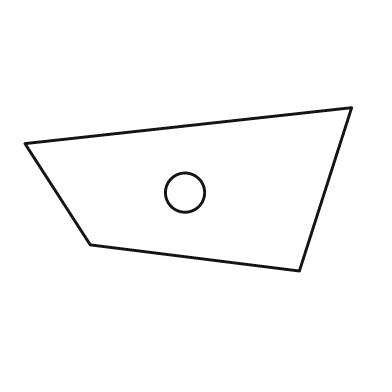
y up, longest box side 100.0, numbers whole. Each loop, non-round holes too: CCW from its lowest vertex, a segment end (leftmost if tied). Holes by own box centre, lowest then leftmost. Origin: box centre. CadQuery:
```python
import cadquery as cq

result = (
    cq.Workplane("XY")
    .moveTo(34.0, -25.0)
    .lineTo(50.0, 25.0)
    .lineTo(-50.0, 14.0)
    .lineTo(-30.0, -17.0)
    .close()
    .moveTo(-1.0, -1.0)
    .circle(6.0)
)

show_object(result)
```